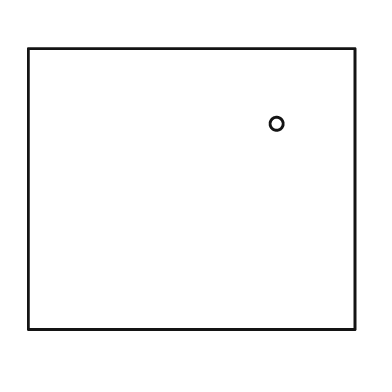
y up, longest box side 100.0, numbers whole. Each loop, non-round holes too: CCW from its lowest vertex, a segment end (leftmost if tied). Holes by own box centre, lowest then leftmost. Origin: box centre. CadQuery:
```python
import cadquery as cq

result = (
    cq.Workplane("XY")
    .moveTo(-50.0, -43.0)
    .lineTo(50.0, -43.0)
    .lineTo(50.0, 43.0)
    .lineTo(-50.0, 43.0)
    .close()
    .moveTo(26.0, 20.0)
    .circle(2.0)
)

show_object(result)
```